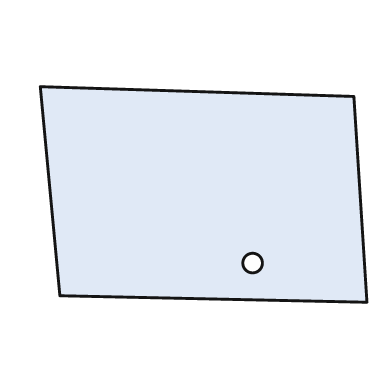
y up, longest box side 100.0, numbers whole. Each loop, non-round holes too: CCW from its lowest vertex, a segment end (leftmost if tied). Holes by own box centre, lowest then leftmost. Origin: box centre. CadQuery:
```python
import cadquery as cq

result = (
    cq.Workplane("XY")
    .moveTo(50.0, -33.0)
    .lineTo(46.0, 30.0)
    .lineTo(-50.0, 33.0)
    .lineTo(-44.0, -31.0)
    .close()
    .moveTo(15.0, -21.0)
    .circle(3.0)
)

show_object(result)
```